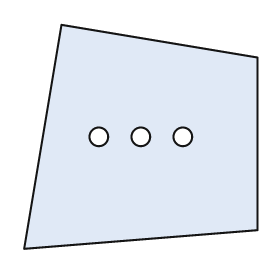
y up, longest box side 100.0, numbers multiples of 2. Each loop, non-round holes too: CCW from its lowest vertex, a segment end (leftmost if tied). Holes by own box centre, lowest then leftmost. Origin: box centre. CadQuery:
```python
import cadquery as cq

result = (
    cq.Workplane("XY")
    .moveTo(-50.0, -48.0)
    .lineTo(50.0, -40.0)
    .lineTo(50.0, 34.0)
    .lineTo(-34.0, 48.0)
    .close()
    .moveTo(-18.0, 0.0)
    .circle(4.0)
    .moveTo(0.0, 0.0)
    .circle(4.0)
    .moveTo(18.0, 0.0)
    .circle(4.0)
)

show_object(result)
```